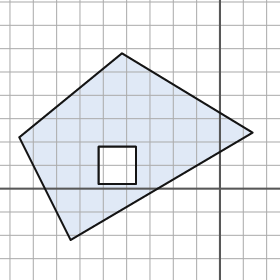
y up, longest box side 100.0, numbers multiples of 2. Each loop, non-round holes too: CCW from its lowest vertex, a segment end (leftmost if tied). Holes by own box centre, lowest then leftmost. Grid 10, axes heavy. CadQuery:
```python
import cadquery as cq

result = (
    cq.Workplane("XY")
    .moveTo(-64.0, -22.0)
    .lineTo(14.0, 24.0)
    .lineTo(-42.0, 58.0)
    .lineTo(-86.0, 22.0)
    .close()
    .moveTo(-52.0, 2.0)
    .lineTo(-36.0, 2.0)
    .lineTo(-36.0, 18.0)
    .lineTo(-52.0, 18.0)
    .close()
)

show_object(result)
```